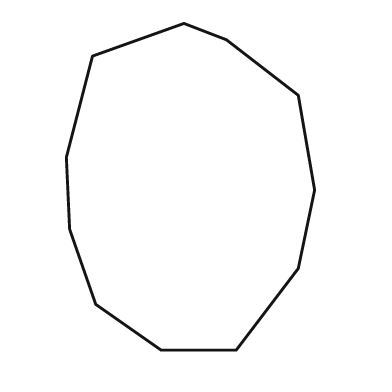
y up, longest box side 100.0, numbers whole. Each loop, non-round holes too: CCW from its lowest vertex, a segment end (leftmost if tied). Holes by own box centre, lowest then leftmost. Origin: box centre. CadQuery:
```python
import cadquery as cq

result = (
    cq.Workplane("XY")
    .moveTo(-9.0, -50.0)
    .lineTo(14.0, -50.0)
    .lineTo(33.0, -25.0)
    .lineTo(38.0, -1.0)
    .lineTo(33.0, 28.0)
    .lineTo(11.0, 45.0)
    .lineTo(-2.0, 50.0)
    .lineTo(-30.0, 40.0)
    .lineTo(-38.0, 9.0)
    .lineTo(-37.0, -13.0)
    .lineTo(-29.0, -36.0)
    .close()
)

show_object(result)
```